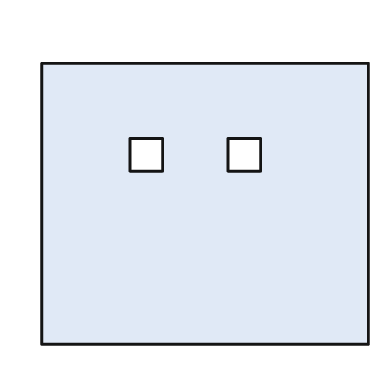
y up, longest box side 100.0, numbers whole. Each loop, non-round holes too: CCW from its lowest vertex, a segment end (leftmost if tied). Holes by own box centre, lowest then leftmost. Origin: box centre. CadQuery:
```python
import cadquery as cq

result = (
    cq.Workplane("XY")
    .moveTo(-50.0, -43.0)
    .lineTo(50.0, -43.0)
    .lineTo(50.0, 43.0)
    .lineTo(-50.0, 43.0)
    .close()
    .moveTo(-23.0, 10.0)
    .lineTo(-13.0, 10.0)
    .lineTo(-13.0, 20.0)
    .lineTo(-23.0, 20.0)
    .close()
    .moveTo(7.0, 10.0)
    .lineTo(17.0, 10.0)
    .lineTo(17.0, 20.0)
    .lineTo(7.0, 20.0)
    .close()
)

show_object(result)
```